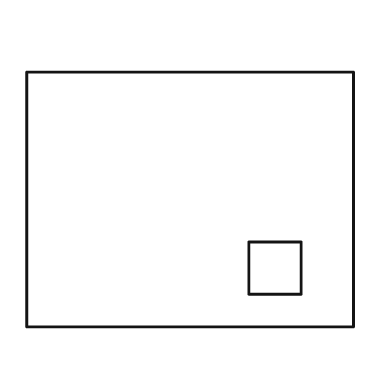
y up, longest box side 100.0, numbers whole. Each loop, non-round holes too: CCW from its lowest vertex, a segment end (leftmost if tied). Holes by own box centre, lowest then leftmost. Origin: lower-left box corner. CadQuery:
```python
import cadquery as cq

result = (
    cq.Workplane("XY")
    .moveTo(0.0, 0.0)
    .lineTo(100.0, 0.0)
    .lineTo(100.0, 78.0)
    .lineTo(0.0, 78.0)
    .close()
    .moveTo(68.0, 10.0)
    .lineTo(84.0, 10.0)
    .lineTo(84.0, 26.0)
    .lineTo(68.0, 26.0)
    .close()
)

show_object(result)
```